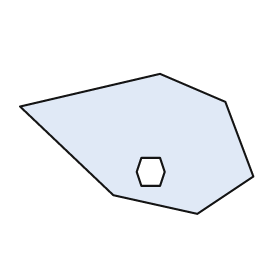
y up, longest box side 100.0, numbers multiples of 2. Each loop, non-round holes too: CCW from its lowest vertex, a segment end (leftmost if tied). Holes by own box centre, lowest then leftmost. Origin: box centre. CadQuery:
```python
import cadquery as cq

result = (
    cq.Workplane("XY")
    .moveTo(26.0, -30.0)
    .lineTo(50.0, -14.0)
    .lineTo(38.0, 18.0)
    .lineTo(10.0, 30.0)
    .lineTo(-50.0, 16.0)
    .lineTo(-10.0, -22.0)
    .close()
    .moveTo(2.0, -18.0)
    .lineTo(10.0, -18.0)
    .lineTo(12.0, -12.0)
    .lineTo(10.0, -6.0)
    .lineTo(2.0, -6.0)
    .lineTo(0.0, -12.0)
    .close()
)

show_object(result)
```